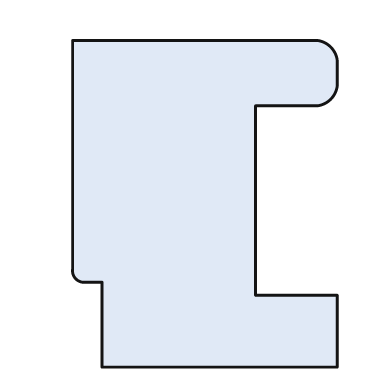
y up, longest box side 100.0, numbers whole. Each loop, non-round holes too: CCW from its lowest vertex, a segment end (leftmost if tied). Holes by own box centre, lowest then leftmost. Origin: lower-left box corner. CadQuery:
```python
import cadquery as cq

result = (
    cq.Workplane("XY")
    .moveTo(9.0, 0.0)
    .lineTo(81.0, 0.0)
    .lineTo(81.0, 22.0)
    .lineTo(56.0, 22.0)
    .lineTo(56.0, 80.0)
    .lineTo(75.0, 80.0)
    .threePointArc((79.0, 82.0), (81.0, 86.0))
    .lineTo(81.0, 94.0)
    .threePointArc((79.0, 98.0), (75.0, 100.0))
    .lineTo(0.0, 100.0)
    .lineTo(0.0, 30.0)
    .threePointArc((1.0, 27.0), (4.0, 26.0))
    .lineTo(9.0, 26.0)
    .close()
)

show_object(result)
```